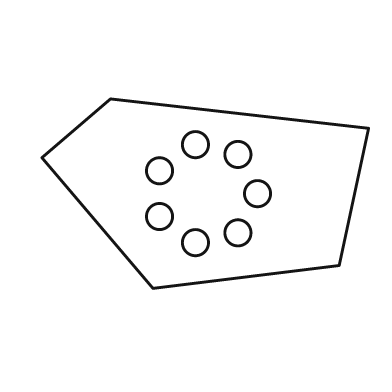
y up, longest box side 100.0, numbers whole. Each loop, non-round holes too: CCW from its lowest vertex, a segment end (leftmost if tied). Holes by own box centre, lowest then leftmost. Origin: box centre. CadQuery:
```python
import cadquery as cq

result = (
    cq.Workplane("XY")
    .moveTo(-16.0, -29.0)
    .lineTo(41.0, -22.0)
    .lineTo(50.0, 20.0)
    .lineTo(-29.0, 29.0)
    .lineTo(-50.0, 11.0)
    .close()
    .moveTo(-3.0, -15.0)
    .circle(4.0)
    .moveTo(10.0, -12.0)
    .circle(4.0)
    .moveTo(-14.0, -7.0)
    .circle(4.0)
    .moveTo(16.0, 0.0)
    .circle(4.0)
    .moveTo(-14.0, 7.0)
    .circle(4.0)
    .moveTo(10.0, 12.0)
    .circle(4.0)
    .moveTo(-3.0, 15.0)
    .circle(4.0)
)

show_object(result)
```